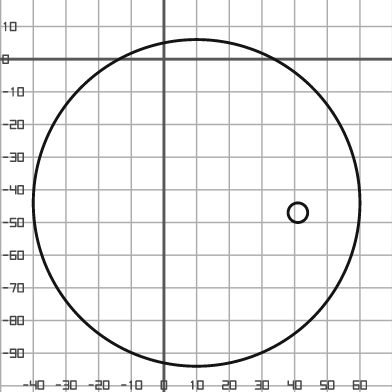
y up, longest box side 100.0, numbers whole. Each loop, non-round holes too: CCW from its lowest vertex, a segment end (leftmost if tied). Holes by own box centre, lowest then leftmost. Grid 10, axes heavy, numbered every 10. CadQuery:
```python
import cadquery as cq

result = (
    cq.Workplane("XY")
    .moveTo(10.0, -44.0)
    .circle(50.0)
    .moveTo(41.0, -47.0)
    .circle(3.0)
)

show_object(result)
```